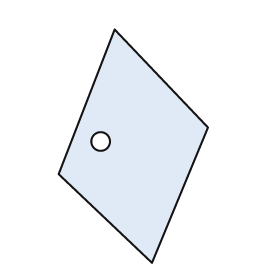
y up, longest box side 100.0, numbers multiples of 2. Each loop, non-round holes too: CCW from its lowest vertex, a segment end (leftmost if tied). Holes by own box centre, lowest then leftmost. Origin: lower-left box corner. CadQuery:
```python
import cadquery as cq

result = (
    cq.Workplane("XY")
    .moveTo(40.0, 0.0)
    .lineTo(64.0, 58.0)
    .lineTo(24.0, 100.0)
    .lineTo(0.0, 38.0)
    .close()
    .moveTo(18.0, 52.0)
    .circle(4.0)
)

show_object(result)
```